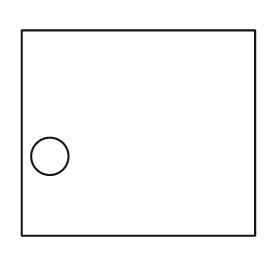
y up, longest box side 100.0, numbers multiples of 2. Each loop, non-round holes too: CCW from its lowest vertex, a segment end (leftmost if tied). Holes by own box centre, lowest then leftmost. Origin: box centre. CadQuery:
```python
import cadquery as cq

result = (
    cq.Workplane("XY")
    .moveTo(-50.0, -44.0)
    .lineTo(50.0, -44.0)
    .lineTo(50.0, 44.0)
    .lineTo(-50.0, 44.0)
    .close()
    .moveTo(-38.0, -10.0)
    .circle(8.0)
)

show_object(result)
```